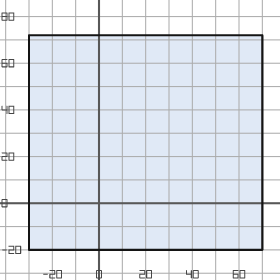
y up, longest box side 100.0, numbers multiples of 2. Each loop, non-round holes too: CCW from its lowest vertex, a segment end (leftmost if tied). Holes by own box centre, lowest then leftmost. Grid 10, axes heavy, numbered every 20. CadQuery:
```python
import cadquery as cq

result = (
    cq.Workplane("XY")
    .moveTo(-30.0, -20.0)
    .lineTo(70.0, -20.0)
    .lineTo(70.0, 72.0)
    .lineTo(-30.0, 72.0)
    .close()
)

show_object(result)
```